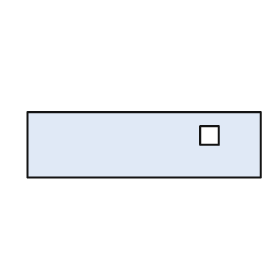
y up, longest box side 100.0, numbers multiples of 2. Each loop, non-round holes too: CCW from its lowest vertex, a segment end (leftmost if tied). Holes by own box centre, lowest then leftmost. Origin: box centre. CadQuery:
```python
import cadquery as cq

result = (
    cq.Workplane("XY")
    .moveTo(-50.0, -14.0)
    .lineTo(50.0, -14.0)
    .lineTo(50.0, 14.0)
    .lineTo(-50.0, 14.0)
    .close()
    .moveTo(24.0, 0.0)
    .lineTo(32.0, 0.0)
    .lineTo(32.0, 8.0)
    .lineTo(24.0, 8.0)
    .close()
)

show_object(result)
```